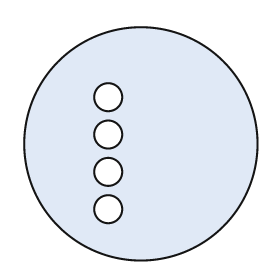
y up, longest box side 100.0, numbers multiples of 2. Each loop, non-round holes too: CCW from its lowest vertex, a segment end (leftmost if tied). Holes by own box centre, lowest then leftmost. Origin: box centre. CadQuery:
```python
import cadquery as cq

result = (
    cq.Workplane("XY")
    .moveTo(0.0, 0.0)
    .circle(50.0)
    .moveTo(-14.0, -28.0)
    .circle(6.0)
    .moveTo(-14.0, -12.0)
    .circle(6.0)
    .moveTo(-14.0, 4.0)
    .circle(6.0)
    .moveTo(-14.0, 20.0)
    .circle(6.0)
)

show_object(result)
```